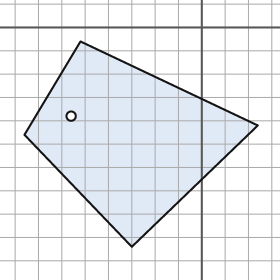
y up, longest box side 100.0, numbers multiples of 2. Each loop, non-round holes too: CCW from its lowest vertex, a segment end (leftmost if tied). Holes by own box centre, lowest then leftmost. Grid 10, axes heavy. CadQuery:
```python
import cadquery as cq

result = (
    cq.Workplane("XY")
    .moveTo(-30.0, -94.0)
    .lineTo(24.0, -42.0)
    .lineTo(-52.0, -6.0)
    .lineTo(-76.0, -46.0)
    .close()
    .moveTo(-56.0, -38.0)
    .circle(2.0)
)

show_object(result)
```